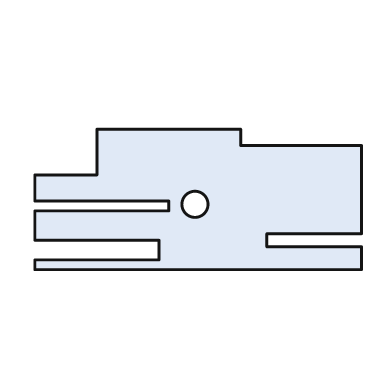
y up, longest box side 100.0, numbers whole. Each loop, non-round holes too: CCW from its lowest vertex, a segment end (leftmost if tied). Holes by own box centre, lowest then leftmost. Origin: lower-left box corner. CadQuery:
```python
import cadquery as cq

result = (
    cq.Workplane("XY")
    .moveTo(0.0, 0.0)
    .lineTo(100.0, 0.0)
    .lineTo(100.0, 7.0)
    .lineTo(71.0, 7.0)
    .lineTo(71.0, 11.0)
    .lineTo(100.0, 11.0)
    .lineTo(100.0, 38.0)
    .lineTo(63.0, 38.0)
    .lineTo(63.0, 43.0)
    .lineTo(19.0, 43.0)
    .lineTo(19.0, 29.0)
    .lineTo(0.0, 29.0)
    .lineTo(0.0, 21.0)
    .lineTo(41.0, 21.0)
    .lineTo(41.0, 18.0)
    .lineTo(0.0, 18.0)
    .lineTo(0.0, 9.0)
    .lineTo(38.0, 9.0)
    .lineTo(38.0, 3.0)
    .lineTo(0.0, 3.0)
    .close()
    .moveTo(49.0, 20.0)
    .circle(4.0)
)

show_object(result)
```